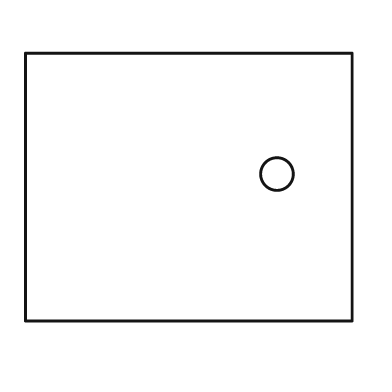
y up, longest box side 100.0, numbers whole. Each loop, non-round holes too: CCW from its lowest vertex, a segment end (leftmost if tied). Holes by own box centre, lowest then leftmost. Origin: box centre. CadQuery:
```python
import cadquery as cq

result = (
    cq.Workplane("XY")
    .moveTo(-50.0, -41.0)
    .lineTo(50.0, -41.0)
    .lineTo(50.0, 41.0)
    .lineTo(-50.0, 41.0)
    .close()
    .moveTo(27.0, 4.0)
    .circle(5.0)
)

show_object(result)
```